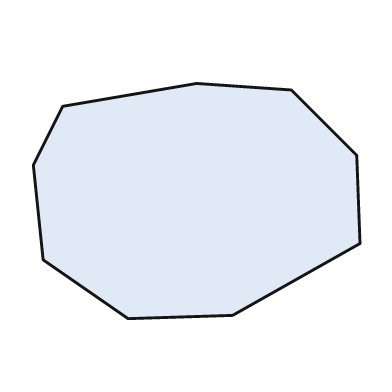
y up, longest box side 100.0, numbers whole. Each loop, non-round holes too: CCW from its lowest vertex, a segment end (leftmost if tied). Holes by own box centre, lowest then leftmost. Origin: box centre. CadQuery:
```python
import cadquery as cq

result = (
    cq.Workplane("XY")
    .moveTo(-21.0, -36.0)
    .lineTo(11.0, -35.0)
    .lineTo(50.0, -13.0)
    .lineTo(49.0, 14.0)
    .lineTo(29.0, 34.0)
    .lineTo(0.0, 36.0)
    .lineTo(-41.0, 29.0)
    .lineTo(-50.0, 11.0)
    .lineTo(-47.0, -18.0)
    .close()
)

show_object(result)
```